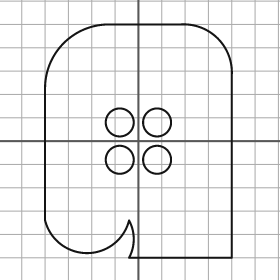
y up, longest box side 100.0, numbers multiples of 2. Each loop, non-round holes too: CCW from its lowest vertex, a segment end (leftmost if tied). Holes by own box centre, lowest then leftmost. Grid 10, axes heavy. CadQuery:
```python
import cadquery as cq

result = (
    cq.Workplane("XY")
    .moveTo(-4.0, -50.0)
    .lineTo(40.0, -50.0)
    .lineTo(40.0, 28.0)
    .threePointArc((34.0, 44.0), (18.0, 50.0))
    .lineTo(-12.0, 50.0)
    .threePointArc((-32.0, 42.0), (-40.0, 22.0))
    .lineTo(-40.0, -34.0)
    .threePointArc((-22.0, -48.0), (-4.0, -34.0))
    .threePointArc((-2.0, -42.0), (-4.0, -50.0))
    .close()
    .moveTo(-8.0, -8.0)
    .circle(6.0)
    .moveTo(8.0, -8.0)
    .circle(6.0)
    .moveTo(-8.0, 8.0)
    .circle(6.0)
    .moveTo(8.0, 8.0)
    .circle(6.0)
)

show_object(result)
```